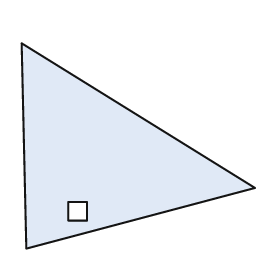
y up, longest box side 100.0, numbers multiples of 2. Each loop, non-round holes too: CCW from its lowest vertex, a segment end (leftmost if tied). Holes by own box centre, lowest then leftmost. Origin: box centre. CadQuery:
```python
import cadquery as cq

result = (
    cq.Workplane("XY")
    .moveTo(-48.0, -44.0)
    .lineTo(50.0, -18.0)
    .lineTo(-50.0, 44.0)
    .close()
    .moveTo(-30.0, -32.0)
    .lineTo(-22.0, -32.0)
    .lineTo(-22.0, -24.0)
    .lineTo(-30.0, -24.0)
    .close()
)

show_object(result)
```